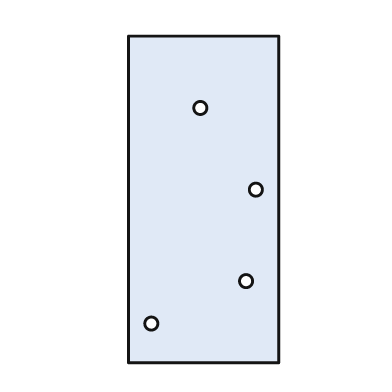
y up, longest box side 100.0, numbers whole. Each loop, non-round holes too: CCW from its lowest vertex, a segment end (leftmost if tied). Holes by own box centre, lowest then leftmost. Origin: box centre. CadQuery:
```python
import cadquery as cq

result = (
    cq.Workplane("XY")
    .moveTo(-23.0, -50.0)
    .lineTo(23.0, -50.0)
    .lineTo(23.0, 50.0)
    .lineTo(-23.0, 50.0)
    .close()
    .moveTo(-16.0, -38.0)
    .circle(2.0)
    .moveTo(13.0, -25.0)
    .circle(2.0)
    .moveTo(16.0, 3.0)
    .circle(2.0)
    .moveTo(-1.0, 28.0)
    .circle(2.0)
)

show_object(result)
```